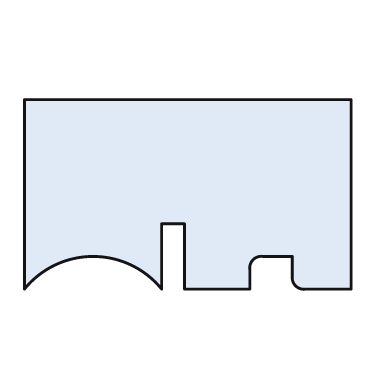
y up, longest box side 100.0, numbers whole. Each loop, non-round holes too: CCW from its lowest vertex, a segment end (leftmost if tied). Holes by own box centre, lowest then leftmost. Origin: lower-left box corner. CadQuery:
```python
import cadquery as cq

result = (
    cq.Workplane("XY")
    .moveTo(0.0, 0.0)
    .threePointArc((21.0, 10.0), (42.0, 0.0))
    .lineTo(42.0, 20.0)
    .lineTo(49.0, 20.0)
    .lineTo(49.0, 0.0)
    .lineTo(69.0, 0.0)
    .lineTo(69.0, 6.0)
    .threePointArc((70.0, 9.0), (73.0, 10.0))
    .lineTo(82.0, 10.0)
    .lineTo(82.0, 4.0)
    .threePointArc((83.0, 1.0), (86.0, 0.0))
    .lineTo(100.0, 0.0)
    .lineTo(100.0, 58.0)
    .lineTo(0.0, 58.0)
    .close()
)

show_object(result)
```